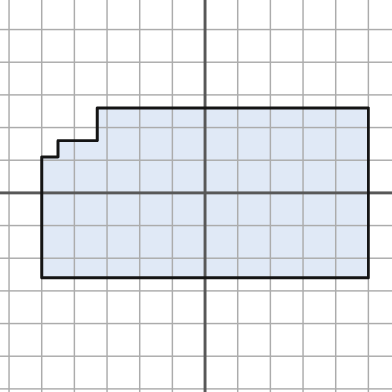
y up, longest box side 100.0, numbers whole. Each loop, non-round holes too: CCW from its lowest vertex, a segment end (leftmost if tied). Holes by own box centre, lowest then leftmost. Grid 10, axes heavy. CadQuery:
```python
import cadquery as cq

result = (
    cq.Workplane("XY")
    .moveTo(-50.0, -26.0)
    .lineTo(50.0, -26.0)
    .lineTo(50.0, 26.0)
    .lineTo(-33.0, 26.0)
    .lineTo(-33.0, 16.0)
    .lineTo(-45.0, 16.0)
    .lineTo(-45.0, 11.0)
    .lineTo(-50.0, 11.0)
    .close()
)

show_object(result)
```